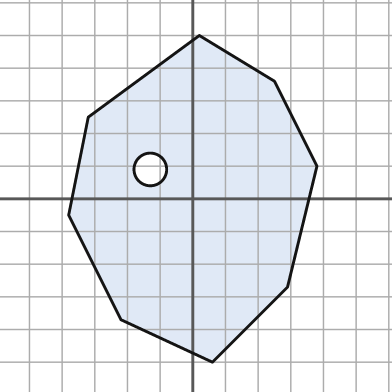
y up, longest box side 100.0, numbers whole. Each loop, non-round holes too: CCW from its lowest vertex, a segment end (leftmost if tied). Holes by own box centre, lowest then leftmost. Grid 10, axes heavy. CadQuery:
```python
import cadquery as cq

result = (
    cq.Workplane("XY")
    .moveTo(6.0, -50.0)
    .lineTo(29.0, -27.0)
    .lineTo(38.0, 10.0)
    .lineTo(25.0, 36.0)
    .lineTo(2.0, 50.0)
    .lineTo(-32.0, 25.0)
    .lineTo(-38.0, -5.0)
    .lineTo(-22.0, -37.0)
    .close()
    .moveTo(-13.0, 9.0)
    .circle(5.0)
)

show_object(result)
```